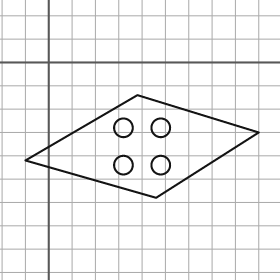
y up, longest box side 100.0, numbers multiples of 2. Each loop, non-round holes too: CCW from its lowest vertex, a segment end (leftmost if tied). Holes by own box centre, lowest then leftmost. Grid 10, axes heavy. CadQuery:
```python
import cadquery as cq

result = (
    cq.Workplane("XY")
    .moveTo(46.0, -58.0)
    .lineTo(90.0, -30.0)
    .lineTo(38.0, -14.0)
    .lineTo(-10.0, -42.0)
    .close()
    .moveTo(32.0, -44.0)
    .circle(4.0)
    .moveTo(48.0, -44.0)
    .circle(4.0)
    .moveTo(32.0, -28.0)
    .circle(4.0)
    .moveTo(48.0, -28.0)
    .circle(4.0)
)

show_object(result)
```